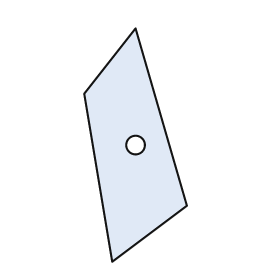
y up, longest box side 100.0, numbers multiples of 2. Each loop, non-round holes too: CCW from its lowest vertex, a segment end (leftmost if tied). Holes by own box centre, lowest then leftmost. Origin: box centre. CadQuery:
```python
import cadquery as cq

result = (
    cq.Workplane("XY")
    .moveTo(-10.0, -50.0)
    .lineTo(22.0, -26.0)
    .lineTo(0.0, 50.0)
    .lineTo(-22.0, 22.0)
    .close()
    .moveTo(0.0, 0.0)
    .circle(4.0)
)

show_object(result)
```